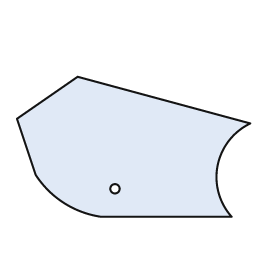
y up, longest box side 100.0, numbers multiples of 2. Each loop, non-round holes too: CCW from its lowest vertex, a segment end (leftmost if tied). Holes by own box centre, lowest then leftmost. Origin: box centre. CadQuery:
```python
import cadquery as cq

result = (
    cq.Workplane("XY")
    .moveTo(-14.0, -30.0)
    .lineTo(42.0, -30.0)
    .threePointArc((36.0, -8.0), (50.0, 10.0))
    .lineTo(-24.0, 30.0)
    .lineTo(-50.0, 12.0)
    .lineTo(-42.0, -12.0)
    .threePointArc((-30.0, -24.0), (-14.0, -30.0))
    .close()
    .moveTo(-8.0, -18.0)
    .circle(2.0)
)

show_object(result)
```